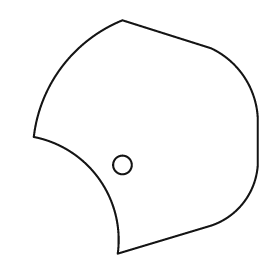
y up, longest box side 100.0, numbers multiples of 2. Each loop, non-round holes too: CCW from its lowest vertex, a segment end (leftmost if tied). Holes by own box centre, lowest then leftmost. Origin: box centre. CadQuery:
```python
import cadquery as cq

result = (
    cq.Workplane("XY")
    .moveTo(-12.0, -50.0)
    .lineTo(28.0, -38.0)
    .threePointArc((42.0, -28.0), (48.0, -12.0))
    .lineTo(48.0, 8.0)
    .threePointArc((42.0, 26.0), (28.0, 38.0))
    .lineTo(-10.0, 50.0)
    .threePointArc((-36.0, 30.0), (-48.0, 0.0))
    .threePointArc((-20.0, -18.0), (-12.0, -50.0))
    .close()
    .moveTo(-10.0, -12.0)
    .circle(4.0)
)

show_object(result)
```